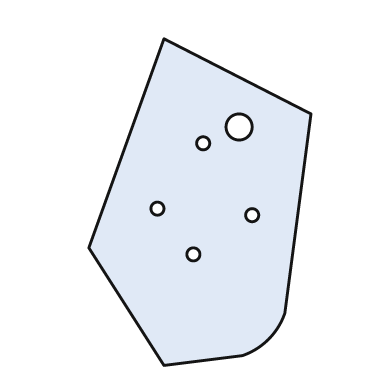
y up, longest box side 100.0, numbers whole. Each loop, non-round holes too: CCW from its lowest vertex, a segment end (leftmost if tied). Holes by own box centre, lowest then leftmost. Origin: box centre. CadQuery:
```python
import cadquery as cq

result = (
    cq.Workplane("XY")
    .moveTo(-11.0, -50.0)
    .lineTo(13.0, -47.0)
    .threePointArc((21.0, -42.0), (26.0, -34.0))
    .lineTo(34.0, 27.0)
    .lineTo(-11.0, 50.0)
    .lineTo(-34.0, -14.0)
    .close()
    .moveTo(-2.0, -16.0)
    .circle(2.0)
    .moveTo(16.0, -4.0)
    .circle(2.0)
    .moveTo(-13.0, -2.0)
    .circle(2.0)
    .moveTo(1.0, 18.0)
    .circle(2.0)
    .moveTo(12.0, 23.0)
    .circle(4.0)
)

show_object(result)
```